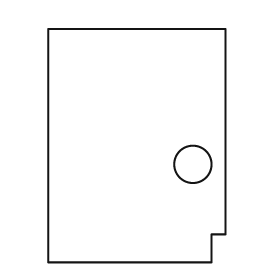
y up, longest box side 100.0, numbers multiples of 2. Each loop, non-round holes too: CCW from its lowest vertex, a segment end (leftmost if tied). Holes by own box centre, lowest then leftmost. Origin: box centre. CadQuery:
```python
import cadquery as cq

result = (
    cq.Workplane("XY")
    .moveTo(-38.0, -50.0)
    .lineTo(32.0, -50.0)
    .lineTo(32.0, -38.0)
    .lineTo(38.0, -38.0)
    .lineTo(38.0, 50.0)
    .lineTo(-38.0, 50.0)
    .close()
    .moveTo(24.0, -8.0)
    .circle(8.0)
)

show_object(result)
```